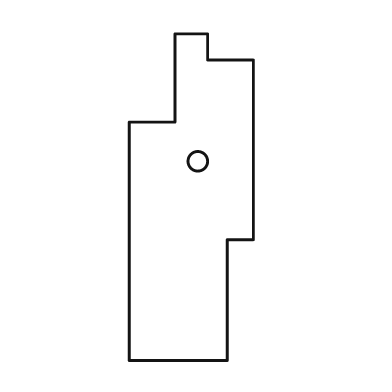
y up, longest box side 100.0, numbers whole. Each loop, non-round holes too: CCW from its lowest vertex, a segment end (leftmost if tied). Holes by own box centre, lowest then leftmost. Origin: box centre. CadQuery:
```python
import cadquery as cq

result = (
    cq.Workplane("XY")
    .moveTo(-19.0, -50.0)
    .lineTo(11.0, -50.0)
    .lineTo(11.0, -13.0)
    .lineTo(19.0, -13.0)
    .lineTo(19.0, 42.0)
    .lineTo(5.0, 42.0)
    .lineTo(5.0, 50.0)
    .lineTo(-5.0, 50.0)
    .lineTo(-5.0, 23.0)
    .lineTo(-19.0, 23.0)
    .close()
    .moveTo(2.0, 11.0)
    .circle(3.0)
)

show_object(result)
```